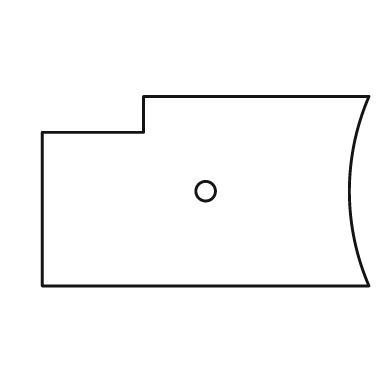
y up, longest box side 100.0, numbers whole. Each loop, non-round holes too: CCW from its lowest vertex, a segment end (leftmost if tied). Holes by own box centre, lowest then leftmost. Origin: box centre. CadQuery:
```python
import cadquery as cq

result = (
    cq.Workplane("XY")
    .moveTo(-50.0, -29.0)
    .lineTo(50.0, -29.0)
    .threePointArc((44.0, 0.0), (50.0, 29.0))
    .lineTo(-19.0, 29.0)
    .lineTo(-19.0, 18.0)
    .lineTo(-50.0, 18.0)
    .close()
    .moveTo(0.0, 0.0)
    .circle(3.0)
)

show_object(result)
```